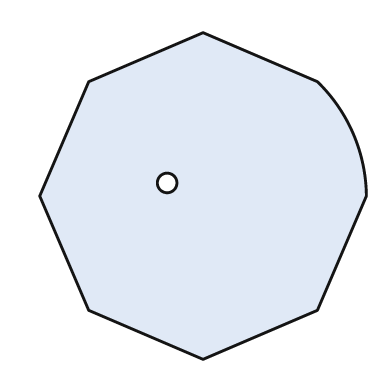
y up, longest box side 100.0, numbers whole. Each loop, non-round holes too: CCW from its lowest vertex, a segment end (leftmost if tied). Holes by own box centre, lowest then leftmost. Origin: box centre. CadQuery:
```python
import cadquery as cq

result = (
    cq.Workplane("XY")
    .moveTo(0.0, -50.0)
    .lineTo(35.0, -35.0)
    .lineTo(50.0, 0.0)
    .threePointArc((46.0, 19.0), (35.0, 35.0))
    .lineTo(0.0, 50.0)
    .lineTo(-35.0, 35.0)
    .lineTo(-50.0, 0.0)
    .lineTo(-35.0, -35.0)
    .close()
    .moveTo(-11.0, 4.0)
    .circle(3.0)
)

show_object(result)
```